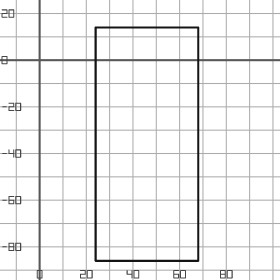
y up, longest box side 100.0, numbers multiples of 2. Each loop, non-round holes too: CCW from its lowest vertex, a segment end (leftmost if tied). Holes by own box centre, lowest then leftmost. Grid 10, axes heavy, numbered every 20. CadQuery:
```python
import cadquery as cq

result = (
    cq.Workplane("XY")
    .moveTo(24.0, -86.0)
    .lineTo(68.0, -86.0)
    .lineTo(68.0, 14.0)
    .lineTo(24.0, 14.0)
    .close()
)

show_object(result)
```